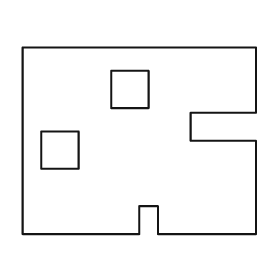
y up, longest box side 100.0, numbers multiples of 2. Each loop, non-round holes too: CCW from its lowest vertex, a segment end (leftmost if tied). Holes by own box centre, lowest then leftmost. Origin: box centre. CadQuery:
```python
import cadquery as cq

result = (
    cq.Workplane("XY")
    .moveTo(-50.0, -40.0)
    .lineTo(0.0, -40.0)
    .lineTo(0.0, -28.0)
    .lineTo(8.0, -28.0)
    .lineTo(8.0, -40.0)
    .lineTo(50.0, -40.0)
    .lineTo(50.0, 0.0)
    .lineTo(22.0, 0.0)
    .lineTo(22.0, 12.0)
    .lineTo(50.0, 12.0)
    .lineTo(50.0, 40.0)
    .lineTo(-50.0, 40.0)
    .close()
    .moveTo(-42.0, -12.0)
    .lineTo(-26.0, -12.0)
    .lineTo(-26.0, 4.0)
    .lineTo(-42.0, 4.0)
    .close()
    .moveTo(-12.0, 14.0)
    .lineTo(4.0, 14.0)
    .lineTo(4.0, 30.0)
    .lineTo(-12.0, 30.0)
    .close()
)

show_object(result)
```